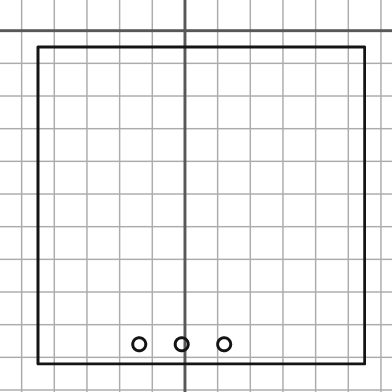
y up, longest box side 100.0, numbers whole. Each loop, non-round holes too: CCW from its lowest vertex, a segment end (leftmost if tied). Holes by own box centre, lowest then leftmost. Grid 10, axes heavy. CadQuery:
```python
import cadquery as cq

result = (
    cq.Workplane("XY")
    .moveTo(-45.0, -102.0)
    .lineTo(55.0, -102.0)
    .lineTo(55.0, -5.0)
    .lineTo(-45.0, -5.0)
    .close()
    .moveTo(-14.0, -96.0)
    .circle(2.0)
    .moveTo(-1.0, -96.0)
    .circle(2.0)
    .moveTo(12.0, -96.0)
    .circle(2.0)
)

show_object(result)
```